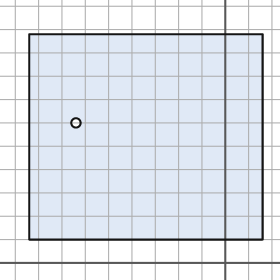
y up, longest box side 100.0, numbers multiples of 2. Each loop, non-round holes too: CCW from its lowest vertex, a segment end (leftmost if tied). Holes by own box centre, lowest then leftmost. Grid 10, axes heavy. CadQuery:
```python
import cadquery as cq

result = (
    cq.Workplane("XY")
    .moveTo(-84.0, 10.0)
    .lineTo(16.0, 10.0)
    .lineTo(16.0, 98.0)
    .lineTo(-84.0, 98.0)
    .close()
    .moveTo(-64.0, 60.0)
    .circle(2.0)
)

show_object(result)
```